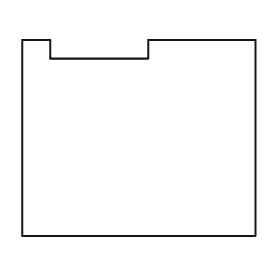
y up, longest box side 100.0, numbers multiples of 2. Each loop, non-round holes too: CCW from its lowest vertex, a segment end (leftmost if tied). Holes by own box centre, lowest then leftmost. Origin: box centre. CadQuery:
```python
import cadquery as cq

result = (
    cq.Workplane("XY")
    .moveTo(-50.0, -42.0)
    .lineTo(50.0, -42.0)
    .lineTo(50.0, 42.0)
    .lineTo(4.0, 42.0)
    .lineTo(4.0, 34.0)
    .lineTo(-38.0, 34.0)
    .lineTo(-38.0, 42.0)
    .lineTo(-50.0, 42.0)
    .close()
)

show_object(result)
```